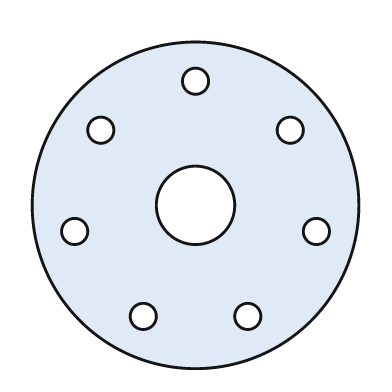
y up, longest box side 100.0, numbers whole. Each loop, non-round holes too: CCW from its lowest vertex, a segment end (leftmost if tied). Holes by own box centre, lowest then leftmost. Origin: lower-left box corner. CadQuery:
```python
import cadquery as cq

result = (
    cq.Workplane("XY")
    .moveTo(50.0, 50.0)
    .circle(50.0)
    .moveTo(34.0, 16.0)
    .circle(4.0)
    .moveTo(66.0, 16.0)
    .circle(4.0)
    .moveTo(13.0, 42.0)
    .circle(4.0)
    .moveTo(87.0, 42.0)
    .circle(4.0)
    .moveTo(50.0, 50.0)
    .circle(12.0)
    .moveTo(21.0, 73.0)
    .circle(4.0)
    .moveTo(79.0, 73.0)
    .circle(4.0)
    .moveTo(50.0, 88.0)
    .circle(4.0)
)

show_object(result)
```